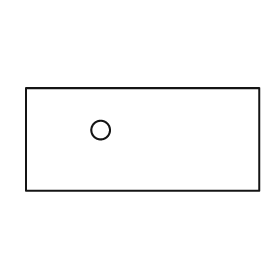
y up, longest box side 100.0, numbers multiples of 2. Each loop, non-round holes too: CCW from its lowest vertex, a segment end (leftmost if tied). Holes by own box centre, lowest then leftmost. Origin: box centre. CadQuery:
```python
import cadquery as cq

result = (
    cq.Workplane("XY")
    .moveTo(-50.0, -22.0)
    .lineTo(50.0, -22.0)
    .lineTo(50.0, 22.0)
    .lineTo(-50.0, 22.0)
    .close()
    .moveTo(-18.0, 4.0)
    .circle(4.0)
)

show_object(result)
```